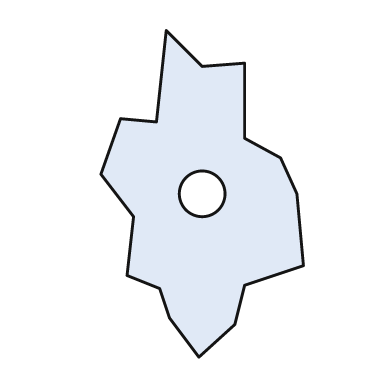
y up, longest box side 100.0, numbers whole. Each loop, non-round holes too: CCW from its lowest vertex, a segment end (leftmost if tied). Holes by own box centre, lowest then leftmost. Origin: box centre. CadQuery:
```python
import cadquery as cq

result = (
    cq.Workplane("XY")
    .moveTo(-1.0, -50.0)
    .lineTo(10.0, -40.0)
    .lineTo(13.0, -28.0)
    .lineTo(31.0, -22.0)
    .lineTo(29.0, 0.0)
    .lineTo(24.0, 11.0)
    .lineTo(13.0, 17.0)
    .lineTo(13.0, 40.0)
    .lineTo(0.0, 39.0)
    .lineTo(-11.0, 50.0)
    .lineTo(-14.0, 22.0)
    .lineTo(-25.0, 23.0)
    .lineTo(-31.0, 6.0)
    .lineTo(-21.0, -7.0)
    .lineTo(-23.0, -25.0)
    .lineTo(-13.0, -29.0)
    .lineTo(-10.0, -38.0)
    .close()
    .moveTo(0.0, 0.0)
    .circle(7.0)
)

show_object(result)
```